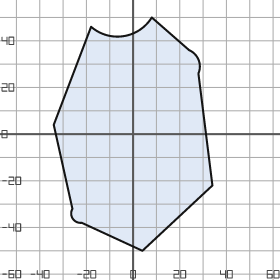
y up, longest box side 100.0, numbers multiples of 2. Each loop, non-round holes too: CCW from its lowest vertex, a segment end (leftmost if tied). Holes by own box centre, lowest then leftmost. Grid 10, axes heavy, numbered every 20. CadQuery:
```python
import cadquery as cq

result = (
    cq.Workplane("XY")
    .moveTo(4.0, -50.0)
    .lineTo(34.0, -22.0)
    .lineTo(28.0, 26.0)
    .threePointArc((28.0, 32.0), (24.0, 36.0))
    .lineTo(8.0, 50.0)
    .threePointArc((-4.0, 42.0), (-18.0, 46.0))
    .lineTo(-34.0, 4.0)
    .lineTo(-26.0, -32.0)
    .threePointArc((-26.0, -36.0), (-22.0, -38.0))
    .close()
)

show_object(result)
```